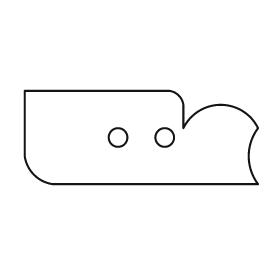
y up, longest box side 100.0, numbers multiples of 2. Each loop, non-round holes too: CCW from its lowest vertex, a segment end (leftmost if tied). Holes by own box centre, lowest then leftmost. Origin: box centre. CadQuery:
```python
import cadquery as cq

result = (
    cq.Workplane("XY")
    .moveTo(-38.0, -20.0)
    .lineTo(50.0, -20.0)
    .threePointArc((46.0, -8.0), (50.0, 4.0))
    .threePointArc((34.0, 14.0), (18.0, 4.0))
    .lineTo(18.0, 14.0)
    .threePointArc((16.0, 18.0), (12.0, 20.0))
    .lineTo(-50.0, 20.0)
    .lineTo(-50.0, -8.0)
    .threePointArc((-46.0, -16.0), (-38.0, -20.0))
    .close()
    .moveTo(-10.0, 0.0)
    .circle(4.0)
    .moveTo(10.0, 0.0)
    .circle(4.0)
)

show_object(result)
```